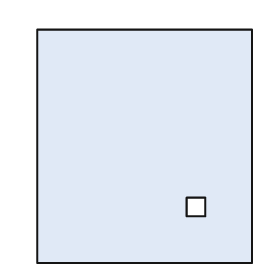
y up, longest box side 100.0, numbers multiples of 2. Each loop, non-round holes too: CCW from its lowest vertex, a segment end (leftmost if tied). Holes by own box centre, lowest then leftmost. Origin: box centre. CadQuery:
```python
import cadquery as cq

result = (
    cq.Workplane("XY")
    .moveTo(-46.0, -50.0)
    .lineTo(46.0, -50.0)
    .lineTo(46.0, 50.0)
    .lineTo(-46.0, 50.0)
    .close()
    .moveTo(18.0, -30.0)
    .lineTo(26.0, -30.0)
    .lineTo(26.0, -22.0)
    .lineTo(18.0, -22.0)
    .close()
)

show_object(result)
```